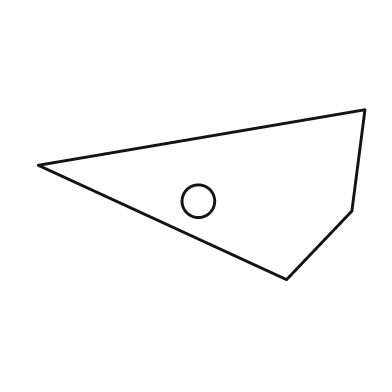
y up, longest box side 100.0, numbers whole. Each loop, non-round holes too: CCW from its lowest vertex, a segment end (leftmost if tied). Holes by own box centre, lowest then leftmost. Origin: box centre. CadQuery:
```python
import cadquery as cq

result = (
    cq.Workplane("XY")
    .moveTo(26.0, -26.0)
    .lineTo(46.0, -5.0)
    .lineTo(50.0, 26.0)
    .lineTo(-50.0, 9.0)
    .close()
    .moveTo(-1.0, -2.0)
    .circle(5.0)
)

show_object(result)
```